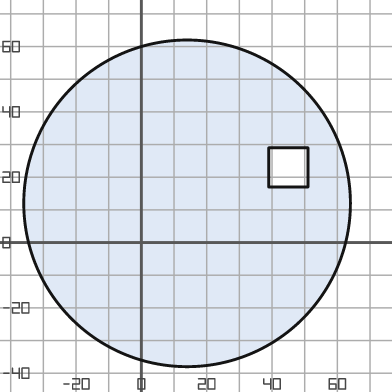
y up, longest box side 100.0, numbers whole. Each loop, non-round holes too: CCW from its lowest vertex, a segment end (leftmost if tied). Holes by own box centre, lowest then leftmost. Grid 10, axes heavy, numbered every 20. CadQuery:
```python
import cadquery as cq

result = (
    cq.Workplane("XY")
    .moveTo(14.0, 12.0)
    .circle(50.0)
    .moveTo(39.0, 17.0)
    .lineTo(51.0, 17.0)
    .lineTo(51.0, 29.0)
    .lineTo(39.0, 29.0)
    .close()
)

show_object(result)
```